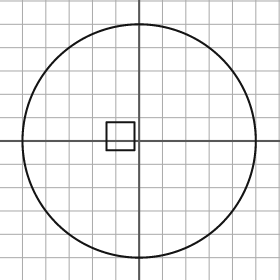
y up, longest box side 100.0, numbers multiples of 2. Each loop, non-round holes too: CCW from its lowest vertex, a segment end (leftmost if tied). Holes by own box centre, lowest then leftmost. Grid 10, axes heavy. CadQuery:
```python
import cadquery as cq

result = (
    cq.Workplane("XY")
    .moveTo(0.0, 0.0)
    .circle(50.0)
    .moveTo(-14.0, -4.0)
    .lineTo(-2.0, -4.0)
    .lineTo(-2.0, 8.0)
    .lineTo(-14.0, 8.0)
    .close()
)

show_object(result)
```